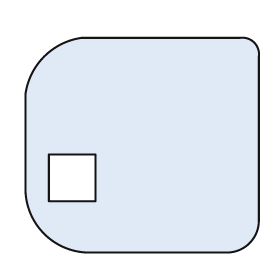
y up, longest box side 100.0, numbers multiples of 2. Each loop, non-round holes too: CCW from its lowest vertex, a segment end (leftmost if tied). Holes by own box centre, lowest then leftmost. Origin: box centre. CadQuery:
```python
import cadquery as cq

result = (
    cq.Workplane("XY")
    .moveTo(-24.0, -46.0)
    .lineTo(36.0, -46.0)
    .threePointArc((46.0, -42.0), (50.0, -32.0))
    .lineTo(50.0, 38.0)
    .threePointArc((48.0, 44.0), (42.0, 46.0))
    .lineTo(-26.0, 46.0)
    .threePointArc((-42.0, 38.0), (-50.0, 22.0))
    .lineTo(-50.0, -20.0)
    .threePointArc((-42.0, -38.0), (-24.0, -46.0))
    .close()
    .moveTo(-40.0, -24.0)
    .lineTo(-20.0, -24.0)
    .lineTo(-20.0, -4.0)
    .lineTo(-40.0, -4.0)
    .close()
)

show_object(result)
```